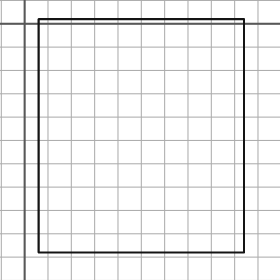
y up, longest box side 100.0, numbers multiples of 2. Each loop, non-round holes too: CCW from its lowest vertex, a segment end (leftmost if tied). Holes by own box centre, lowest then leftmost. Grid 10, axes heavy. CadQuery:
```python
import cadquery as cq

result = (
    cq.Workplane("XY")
    .moveTo(6.0, -98.0)
    .lineTo(94.0, -98.0)
    .lineTo(94.0, 2.0)
    .lineTo(6.0, 2.0)
    .close()
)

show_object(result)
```